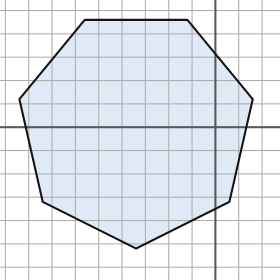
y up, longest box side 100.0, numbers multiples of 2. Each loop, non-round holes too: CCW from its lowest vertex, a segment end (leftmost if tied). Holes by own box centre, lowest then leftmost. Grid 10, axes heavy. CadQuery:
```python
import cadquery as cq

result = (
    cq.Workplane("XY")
    .moveTo(-34.0, -52.0)
    .lineTo(6.0, -32.0)
    .lineTo(16.0, 12.0)
    .lineTo(-12.0, 46.0)
    .lineTo(-56.0, 46.0)
    .lineTo(-84.0, 12.0)
    .lineTo(-74.0, -32.0)
    .close()
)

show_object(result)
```